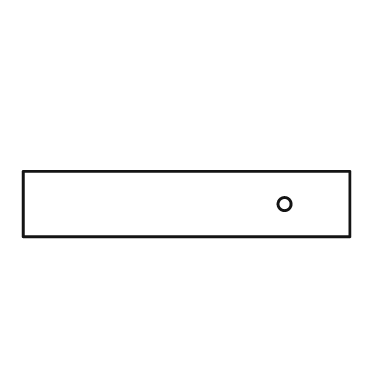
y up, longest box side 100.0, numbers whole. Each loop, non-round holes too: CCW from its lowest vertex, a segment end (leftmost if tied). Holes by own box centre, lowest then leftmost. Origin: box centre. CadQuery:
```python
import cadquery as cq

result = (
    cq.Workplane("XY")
    .moveTo(-50.0, -10.0)
    .lineTo(50.0, -10.0)
    .lineTo(50.0, 10.0)
    .lineTo(-50.0, 10.0)
    .close()
    .moveTo(30.0, 0.0)
    .circle(2.0)
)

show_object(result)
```